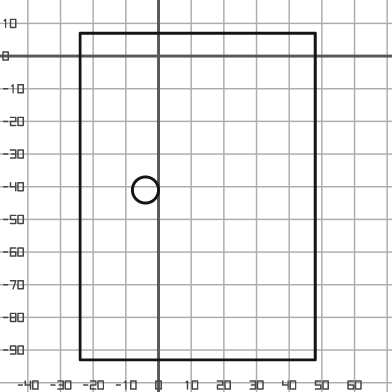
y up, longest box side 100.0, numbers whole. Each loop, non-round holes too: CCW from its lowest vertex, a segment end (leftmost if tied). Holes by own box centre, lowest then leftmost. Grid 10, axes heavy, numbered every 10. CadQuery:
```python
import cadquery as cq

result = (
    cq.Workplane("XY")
    .moveTo(-24.0, -93.0)
    .lineTo(48.0, -93.0)
    .lineTo(48.0, 7.0)
    .lineTo(-24.0, 7.0)
    .close()
    .moveTo(-4.0, -41.0)
    .circle(4.0)
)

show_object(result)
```